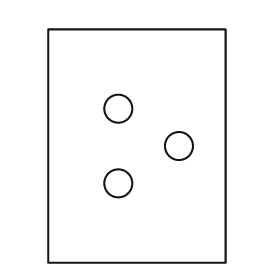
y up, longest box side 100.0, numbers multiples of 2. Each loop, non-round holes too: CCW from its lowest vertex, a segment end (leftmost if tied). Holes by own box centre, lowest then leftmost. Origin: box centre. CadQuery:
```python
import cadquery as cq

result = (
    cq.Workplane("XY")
    .moveTo(-38.0, -50.0)
    .lineTo(38.0, -50.0)
    .lineTo(38.0, 50.0)
    .lineTo(-38.0, 50.0)
    .close()
    .moveTo(-8.0, -16.0)
    .circle(6.0)
    .moveTo(18.0, 0.0)
    .circle(6.0)
    .moveTo(-8.0, 16.0)
    .circle(6.0)
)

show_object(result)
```